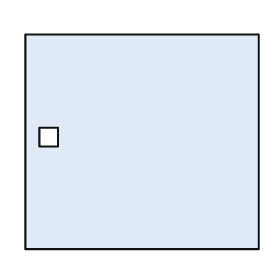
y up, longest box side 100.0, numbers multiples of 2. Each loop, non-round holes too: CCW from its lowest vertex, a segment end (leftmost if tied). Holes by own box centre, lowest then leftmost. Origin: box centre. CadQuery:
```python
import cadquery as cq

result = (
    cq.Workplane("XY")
    .moveTo(-50.0, -46.0)
    .lineTo(50.0, -46.0)
    .lineTo(50.0, 46.0)
    .lineTo(-50.0, 46.0)
    .close()
    .moveTo(-44.0, -2.0)
    .lineTo(-36.0, -2.0)
    .lineTo(-36.0, 6.0)
    .lineTo(-44.0, 6.0)
    .close()
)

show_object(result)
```